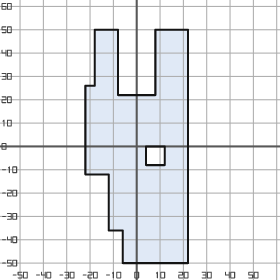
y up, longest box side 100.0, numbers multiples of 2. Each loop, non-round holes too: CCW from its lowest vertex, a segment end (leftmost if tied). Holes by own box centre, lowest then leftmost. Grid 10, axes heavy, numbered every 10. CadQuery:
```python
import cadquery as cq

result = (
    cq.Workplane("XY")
    .moveTo(-6.0, -50.0)
    .lineTo(22.0, -50.0)
    .lineTo(22.0, 50.0)
    .lineTo(8.0, 50.0)
    .lineTo(8.0, 22.0)
    .lineTo(-8.0, 22.0)
    .lineTo(-8.0, 50.0)
    .lineTo(-18.0, 50.0)
    .lineTo(-18.0, 26.0)
    .lineTo(-22.0, 26.0)
    .lineTo(-22.0, -12.0)
    .lineTo(-12.0, -12.0)
    .lineTo(-12.0, -36.0)
    .lineTo(-6.0, -36.0)
    .close()
    .moveTo(4.0, -8.0)
    .lineTo(12.0, -8.0)
    .lineTo(12.0, 0.0)
    .lineTo(4.0, 0.0)
    .close()
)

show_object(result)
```